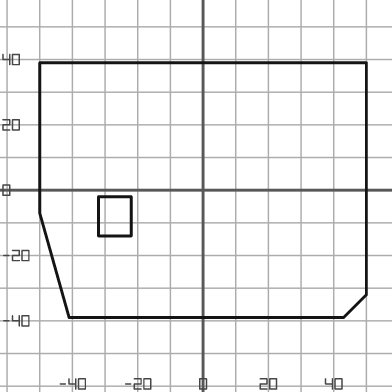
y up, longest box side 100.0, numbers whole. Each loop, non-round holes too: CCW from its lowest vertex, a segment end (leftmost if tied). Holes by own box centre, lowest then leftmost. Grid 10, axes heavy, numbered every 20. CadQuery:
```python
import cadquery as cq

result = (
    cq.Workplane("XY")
    .moveTo(-41.0, -39.0)
    .lineTo(43.0, -39.0)
    .lineTo(50.0, -32.0)
    .lineTo(50.0, 39.0)
    .lineTo(-50.0, 39.0)
    .lineTo(-50.0, -7.0)
    .close()
    .moveTo(-32.0, -14.0)
    .lineTo(-22.0, -14.0)
    .lineTo(-22.0, -2.0)
    .lineTo(-32.0, -2.0)
    .close()
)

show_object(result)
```